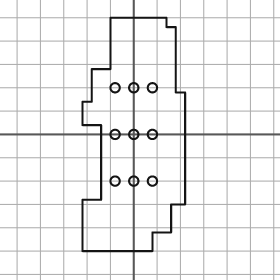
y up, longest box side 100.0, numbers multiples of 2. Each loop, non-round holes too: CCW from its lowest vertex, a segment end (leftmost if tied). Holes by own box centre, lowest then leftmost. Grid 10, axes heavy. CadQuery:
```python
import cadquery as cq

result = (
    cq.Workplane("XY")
    .moveTo(-22.0, -50.0)
    .lineTo(8.0, -50.0)
    .lineTo(8.0, -42.0)
    .lineTo(16.0, -42.0)
    .lineTo(16.0, -30.0)
    .lineTo(22.0, -30.0)
    .lineTo(22.0, 18.0)
    .lineTo(18.0, 18.0)
    .lineTo(18.0, 46.0)
    .lineTo(14.0, 46.0)
    .lineTo(14.0, 50.0)
    .lineTo(-10.0, 50.0)
    .lineTo(-10.0, 28.0)
    .lineTo(-18.0, 28.0)
    .lineTo(-18.0, 14.0)
    .lineTo(-22.0, 14.0)
    .lineTo(-22.0, 4.0)
    .lineTo(-14.0, 4.0)
    .lineTo(-14.0, -28.0)
    .lineTo(-22.0, -28.0)
    .close()
    .moveTo(-8.0, -20.0)
    .circle(2.0)
    .moveTo(0.0, -20.0)
    .circle(2.0)
    .moveTo(8.0, -20.0)
    .circle(2.0)
    .moveTo(-8.0, 0.0)
    .circle(2.0)
    .moveTo(0.0, 0.0)
    .circle(2.0)
    .moveTo(8.0, 0.0)
    .circle(2.0)
    .moveTo(-8.0, 20.0)
    .circle(2.0)
    .moveTo(0.0, 20.0)
    .circle(2.0)
    .moveTo(8.0, 20.0)
    .circle(2.0)
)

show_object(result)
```